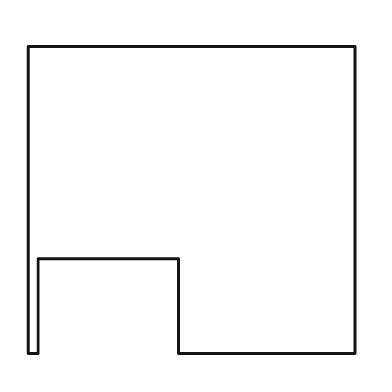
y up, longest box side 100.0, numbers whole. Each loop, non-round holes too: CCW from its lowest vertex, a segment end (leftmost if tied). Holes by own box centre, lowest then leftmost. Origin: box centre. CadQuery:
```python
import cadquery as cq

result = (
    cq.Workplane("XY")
    .moveTo(-50.0, -47.0)
    .lineTo(-47.0, -47.0)
    .lineTo(-47.0, -18.0)
    .lineTo(-4.0, -18.0)
    .lineTo(-4.0, -47.0)
    .lineTo(50.0, -47.0)
    .lineTo(50.0, 47.0)
    .lineTo(-50.0, 47.0)
    .close()
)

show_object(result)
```